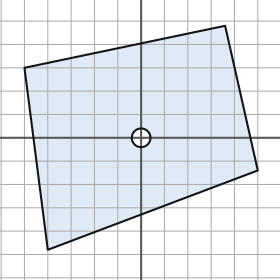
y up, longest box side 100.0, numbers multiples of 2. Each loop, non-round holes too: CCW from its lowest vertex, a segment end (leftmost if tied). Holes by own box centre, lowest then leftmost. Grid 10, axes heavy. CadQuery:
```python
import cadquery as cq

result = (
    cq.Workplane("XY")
    .moveTo(-40.0, -48.0)
    .lineTo(50.0, -14.0)
    .lineTo(36.0, 48.0)
    .lineTo(-50.0, 30.0)
    .close()
    .moveTo(0.0, 0.0)
    .circle(4.0)
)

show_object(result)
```